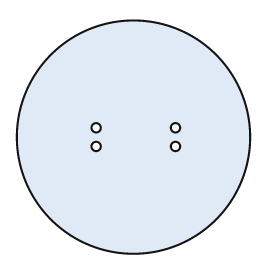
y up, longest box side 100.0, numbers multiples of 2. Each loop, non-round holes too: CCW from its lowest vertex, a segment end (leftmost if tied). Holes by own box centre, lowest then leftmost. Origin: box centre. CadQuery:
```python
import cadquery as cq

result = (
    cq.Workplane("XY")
    .moveTo(0.0, 0.0)
    .circle(50.0)
    .moveTo(-16.0, -4.0)
    .circle(2.0)
    .moveTo(18.0, -4.0)
    .circle(2.0)
    .moveTo(-16.0, 4.0)
    .circle(2.0)
    .moveTo(18.0, 4.0)
    .circle(2.0)
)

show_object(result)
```